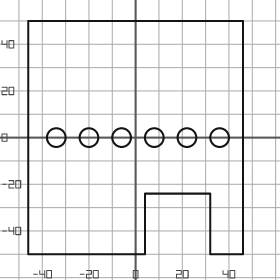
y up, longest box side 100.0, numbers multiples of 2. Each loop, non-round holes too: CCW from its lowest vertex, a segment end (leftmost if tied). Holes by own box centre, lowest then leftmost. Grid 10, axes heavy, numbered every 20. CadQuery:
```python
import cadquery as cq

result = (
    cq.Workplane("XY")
    .moveTo(-46.0, -50.0)
    .lineTo(4.0, -50.0)
    .lineTo(4.0, -24.0)
    .lineTo(32.0, -24.0)
    .lineTo(32.0, -50.0)
    .lineTo(46.0, -50.0)
    .lineTo(46.0, 50.0)
    .lineTo(-46.0, 50.0)
    .close()
    .moveTo(-34.0, 0.0)
    .circle(4.0)
    .moveTo(-20.0, 0.0)
    .circle(4.0)
    .moveTo(-6.0, 0.0)
    .circle(4.0)
    .moveTo(8.0, 0.0)
    .circle(4.0)
    .moveTo(22.0, 0.0)
    .circle(4.0)
    .moveTo(36.0, 0.0)
    .circle(4.0)
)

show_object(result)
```